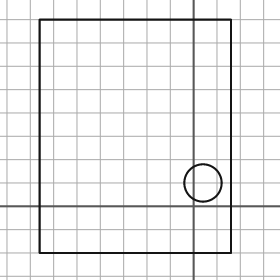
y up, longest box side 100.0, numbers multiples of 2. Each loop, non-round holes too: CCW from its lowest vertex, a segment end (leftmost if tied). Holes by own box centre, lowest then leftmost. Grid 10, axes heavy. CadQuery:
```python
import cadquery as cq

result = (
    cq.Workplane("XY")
    .moveTo(-66.0, -20.0)
    .lineTo(16.0, -20.0)
    .lineTo(16.0, 80.0)
    .lineTo(-66.0, 80.0)
    .close()
    .moveTo(4.0, 10.0)
    .circle(8.0)
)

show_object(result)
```